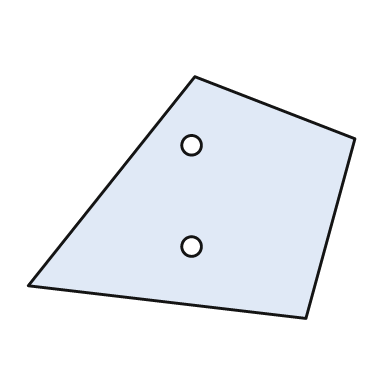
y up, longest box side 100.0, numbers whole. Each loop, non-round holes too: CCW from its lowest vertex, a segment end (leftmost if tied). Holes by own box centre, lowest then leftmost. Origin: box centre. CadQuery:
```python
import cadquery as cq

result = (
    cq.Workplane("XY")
    .moveTo(35.0, -37.0)
    .lineTo(50.0, 18.0)
    .lineTo(1.0, 37.0)
    .lineTo(-50.0, -27.0)
    .close()
    .moveTo(0.0, -15.0)
    .circle(3.0)
    .moveTo(0.0, 16.0)
    .circle(3.0)
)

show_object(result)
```